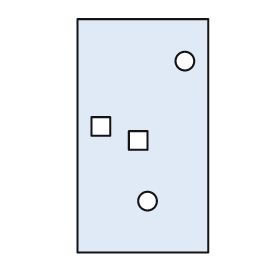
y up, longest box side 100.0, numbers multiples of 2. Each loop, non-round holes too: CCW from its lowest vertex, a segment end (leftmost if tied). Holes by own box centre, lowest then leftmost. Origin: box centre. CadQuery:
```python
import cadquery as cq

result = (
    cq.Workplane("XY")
    .moveTo(-28.0, -50.0)
    .lineTo(28.0, -50.0)
    .lineTo(28.0, 50.0)
    .lineTo(-28.0, 50.0)
    .close()
    .moveTo(2.0, -28.0)
    .circle(4.0)
    .moveTo(-6.0, -6.0)
    .lineTo(2.0, -6.0)
    .lineTo(2.0, 2.0)
    .lineTo(-6.0, 2.0)
    .close()
    .moveTo(-22.0, 0.0)
    .lineTo(-14.0, 0.0)
    .lineTo(-14.0, 8.0)
    .lineTo(-22.0, 8.0)
    .close()
    .moveTo(18.0, 32.0)
    .circle(4.0)
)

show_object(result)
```